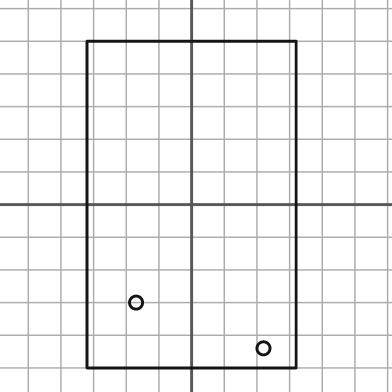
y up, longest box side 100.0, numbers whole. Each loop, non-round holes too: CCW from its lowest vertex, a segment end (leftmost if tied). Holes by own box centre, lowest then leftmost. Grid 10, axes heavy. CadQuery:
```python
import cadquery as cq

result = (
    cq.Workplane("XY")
    .moveTo(-32.0, -50.0)
    .lineTo(32.0, -50.0)
    .lineTo(32.0, 50.0)
    .lineTo(-32.0, 50.0)
    .close()
    .moveTo(22.0, -44.0)
    .circle(2.0)
    .moveTo(-17.0, -30.0)
    .circle(2.0)
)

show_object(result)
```